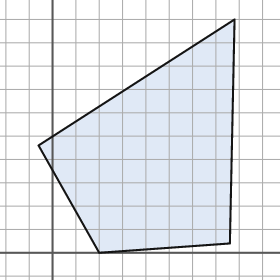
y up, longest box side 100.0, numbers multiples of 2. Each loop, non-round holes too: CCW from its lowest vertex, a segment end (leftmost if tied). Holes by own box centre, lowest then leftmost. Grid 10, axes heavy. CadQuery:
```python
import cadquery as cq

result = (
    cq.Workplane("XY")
    .moveTo(20.0, 0.0)
    .lineTo(76.0, 4.0)
    .lineTo(78.0, 100.0)
    .lineTo(-6.0, 46.0)
    .close()
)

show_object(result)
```